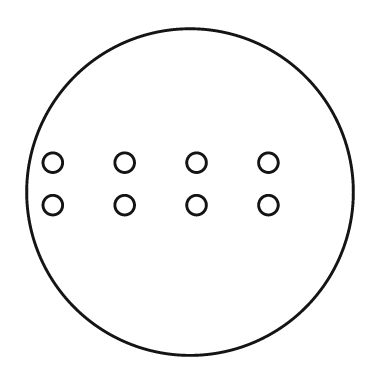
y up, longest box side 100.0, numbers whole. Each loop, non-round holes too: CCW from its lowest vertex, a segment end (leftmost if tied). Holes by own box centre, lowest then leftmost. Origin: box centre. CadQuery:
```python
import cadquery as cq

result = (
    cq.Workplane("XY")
    .moveTo(0.0, 0.0)
    .circle(50.0)
    .moveTo(-42.0, -4.0)
    .circle(3.0)
    .moveTo(-20.0, -4.0)
    .circle(3.0)
    .moveTo(2.0, -4.0)
    .circle(3.0)
    .moveTo(24.0, -4.0)
    .circle(3.0)
    .moveTo(-42.0, 9.0)
    .circle(3.0)
    .moveTo(-20.0, 9.0)
    .circle(3.0)
    .moveTo(2.0, 9.0)
    .circle(3.0)
    .moveTo(24.0, 9.0)
    .circle(3.0)
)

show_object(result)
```